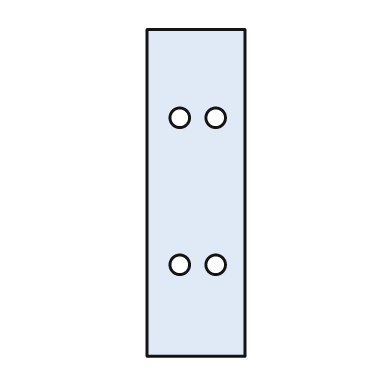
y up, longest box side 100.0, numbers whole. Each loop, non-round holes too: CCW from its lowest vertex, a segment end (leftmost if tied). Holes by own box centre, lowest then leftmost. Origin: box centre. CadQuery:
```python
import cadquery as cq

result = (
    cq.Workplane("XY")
    .moveTo(-15.0, -50.0)
    .lineTo(15.0, -50.0)
    .lineTo(15.0, 50.0)
    .lineTo(-15.0, 50.0)
    .close()
    .moveTo(-5.0, -22.0)
    .circle(3.0)
    .moveTo(6.0, -22.0)
    .circle(3.0)
    .moveTo(-5.0, 23.0)
    .circle(3.0)
    .moveTo(6.0, 23.0)
    .circle(3.0)
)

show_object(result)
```